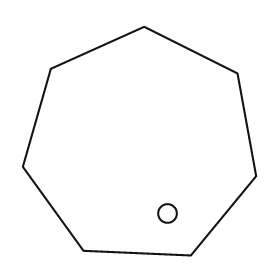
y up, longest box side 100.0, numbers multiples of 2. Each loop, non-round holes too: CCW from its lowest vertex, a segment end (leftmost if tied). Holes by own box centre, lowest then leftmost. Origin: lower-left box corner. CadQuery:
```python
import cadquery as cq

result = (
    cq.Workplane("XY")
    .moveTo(72.0, 0.0)
    .lineTo(100.0, 34.0)
    .lineTo(92.0, 78.0)
    .lineTo(52.0, 98.0)
    .lineTo(12.0, 80.0)
    .lineTo(0.0, 38.0)
    .lineTo(26.0, 2.0)
    .close()
    .moveTo(62.0, 18.0)
    .circle(4.0)
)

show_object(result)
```